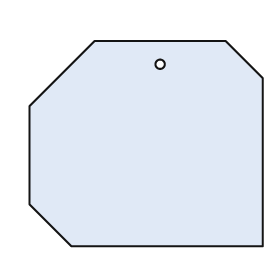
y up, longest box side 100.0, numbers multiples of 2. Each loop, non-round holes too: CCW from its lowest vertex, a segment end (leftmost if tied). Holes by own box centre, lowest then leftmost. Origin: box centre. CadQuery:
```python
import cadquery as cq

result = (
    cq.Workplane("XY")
    .moveTo(-32.0, -44.0)
    .lineTo(50.0, -44.0)
    .lineTo(50.0, 28.0)
    .lineTo(34.0, 44.0)
    .lineTo(-22.0, 44.0)
    .lineTo(-50.0, 16.0)
    .lineTo(-50.0, -26.0)
    .close()
    .moveTo(6.0, 34.0)
    .circle(2.0)
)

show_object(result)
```